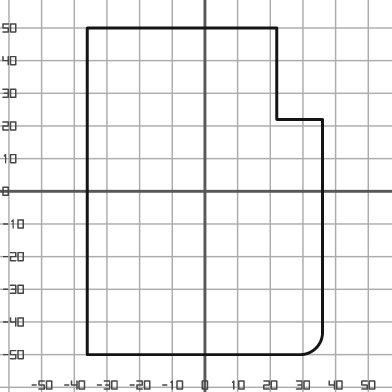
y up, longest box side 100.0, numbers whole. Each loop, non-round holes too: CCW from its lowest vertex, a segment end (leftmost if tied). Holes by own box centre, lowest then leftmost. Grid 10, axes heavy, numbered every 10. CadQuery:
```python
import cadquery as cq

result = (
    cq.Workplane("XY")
    .moveTo(-36.0, -50.0)
    .lineTo(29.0, -50.0)
    .threePointArc((34.0, -48.0), (36.0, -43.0))
    .lineTo(36.0, 22.0)
    .lineTo(22.0, 22.0)
    .lineTo(22.0, 50.0)
    .lineTo(-36.0, 50.0)
    .close()
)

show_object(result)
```